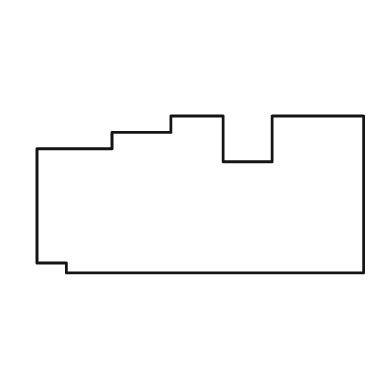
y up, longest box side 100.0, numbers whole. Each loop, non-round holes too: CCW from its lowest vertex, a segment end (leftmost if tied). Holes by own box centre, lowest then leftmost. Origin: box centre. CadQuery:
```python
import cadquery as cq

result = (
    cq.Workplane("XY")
    .moveTo(-41.0, -24.0)
    .lineTo(50.0, -24.0)
    .lineTo(50.0, 24.0)
    .lineTo(22.0, 24.0)
    .lineTo(22.0, 10.0)
    .lineTo(7.0, 10.0)
    .lineTo(7.0, 24.0)
    .lineTo(-9.0, 24.0)
    .lineTo(-9.0, 19.0)
    .lineTo(-27.0, 19.0)
    .lineTo(-27.0, 14.0)
    .lineTo(-50.0, 14.0)
    .lineTo(-50.0, -21.0)
    .lineTo(-41.0, -21.0)
    .close()
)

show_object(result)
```